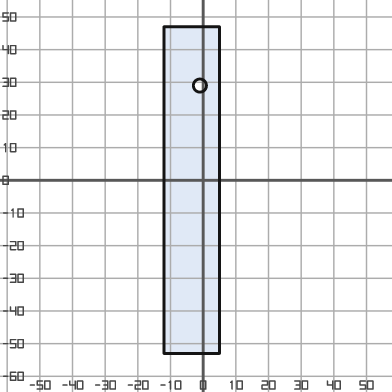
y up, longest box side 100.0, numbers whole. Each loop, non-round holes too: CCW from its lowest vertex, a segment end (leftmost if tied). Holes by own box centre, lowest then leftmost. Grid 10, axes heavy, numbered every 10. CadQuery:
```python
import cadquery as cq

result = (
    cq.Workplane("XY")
    .moveTo(-12.0, -53.0)
    .lineTo(5.0, -53.0)
    .lineTo(5.0, 47.0)
    .lineTo(-12.0, 47.0)
    .close()
    .moveTo(-1.0, 29.0)
    .circle(2.0)
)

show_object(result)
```